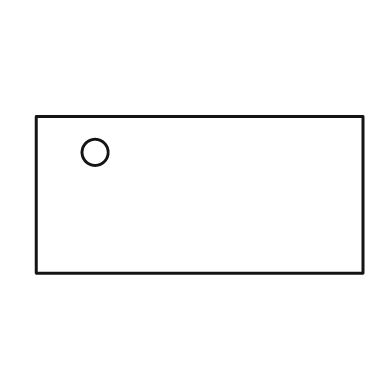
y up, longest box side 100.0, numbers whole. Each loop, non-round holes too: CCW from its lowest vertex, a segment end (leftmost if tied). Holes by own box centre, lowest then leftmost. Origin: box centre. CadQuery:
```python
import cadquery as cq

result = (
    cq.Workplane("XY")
    .moveTo(-50.0, -24.0)
    .lineTo(50.0, -24.0)
    .lineTo(50.0, 24.0)
    .lineTo(-50.0, 24.0)
    .close()
    .moveTo(-32.0, 13.0)
    .circle(4.0)
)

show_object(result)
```